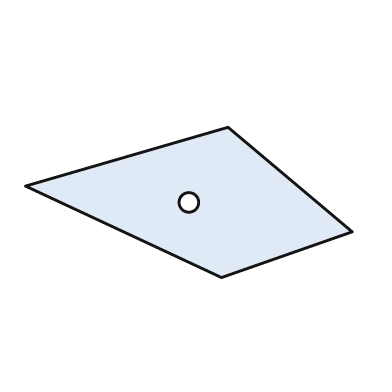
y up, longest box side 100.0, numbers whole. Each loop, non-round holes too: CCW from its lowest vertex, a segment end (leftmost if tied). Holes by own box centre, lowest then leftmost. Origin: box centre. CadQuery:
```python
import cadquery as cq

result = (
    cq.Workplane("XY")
    .moveTo(10.0, -23.0)
    .lineTo(50.0, -9.0)
    .lineTo(12.0, 23.0)
    .lineTo(-50.0, 5.0)
    .close()
    .moveTo(0.0, 0.0)
    .circle(3.0)
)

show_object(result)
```